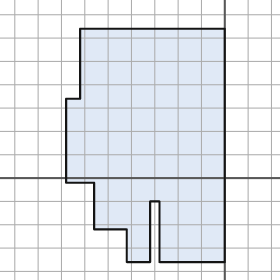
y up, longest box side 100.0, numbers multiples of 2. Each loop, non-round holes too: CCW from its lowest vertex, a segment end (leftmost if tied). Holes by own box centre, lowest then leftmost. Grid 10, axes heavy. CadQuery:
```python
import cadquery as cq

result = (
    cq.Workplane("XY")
    .moveTo(-42.0, -36.0)
    .lineTo(-32.0, -36.0)
    .lineTo(-32.0, -10.0)
    .lineTo(-28.0, -10.0)
    .lineTo(-28.0, -36.0)
    .lineTo(0.0, -36.0)
    .lineTo(0.0, 64.0)
    .lineTo(-62.0, 64.0)
    .lineTo(-62.0, 34.0)
    .lineTo(-68.0, 34.0)
    .lineTo(-68.0, -2.0)
    .lineTo(-56.0, -2.0)
    .lineTo(-56.0, -22.0)
    .lineTo(-42.0, -22.0)
    .close()
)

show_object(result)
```